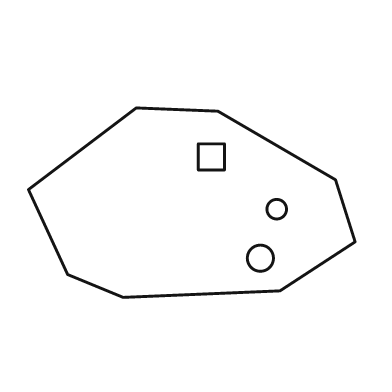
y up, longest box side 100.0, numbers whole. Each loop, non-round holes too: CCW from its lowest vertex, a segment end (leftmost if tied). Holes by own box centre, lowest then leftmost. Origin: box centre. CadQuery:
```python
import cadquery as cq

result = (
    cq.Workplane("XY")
    .moveTo(-21.0, -29.0)
    .lineTo(27.0, -27.0)
    .lineTo(50.0, -12.0)
    .lineTo(44.0, 7.0)
    .lineTo(8.0, 28.0)
    .lineTo(-17.0, 29.0)
    .lineTo(-50.0, 4.0)
    .lineTo(-38.0, -22.0)
    .close()
    .moveTo(21.0, -17.0)
    .circle(4.0)
    .moveTo(26.0, -2.0)
    .circle(3.0)
    .moveTo(2.0, 10.0)
    .lineTo(10.0, 10.0)
    .lineTo(10.0, 18.0)
    .lineTo(2.0, 18.0)
    .close()
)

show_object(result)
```